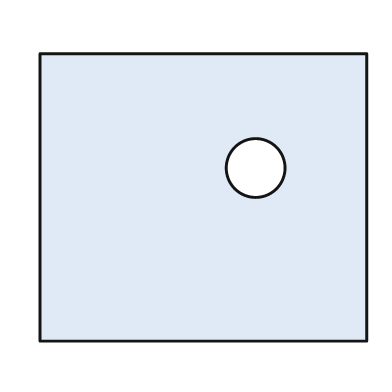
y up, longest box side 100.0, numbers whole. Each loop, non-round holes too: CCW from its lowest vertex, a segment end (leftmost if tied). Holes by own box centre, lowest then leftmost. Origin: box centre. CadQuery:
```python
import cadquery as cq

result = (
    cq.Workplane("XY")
    .moveTo(-50.0, -44.0)
    .lineTo(50.0, -44.0)
    .lineTo(50.0, 44.0)
    .lineTo(-50.0, 44.0)
    .close()
    .moveTo(16.0, 9.0)
    .circle(9.0)
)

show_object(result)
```